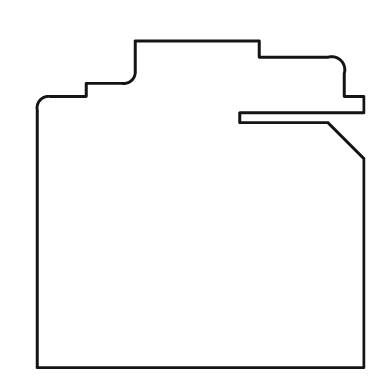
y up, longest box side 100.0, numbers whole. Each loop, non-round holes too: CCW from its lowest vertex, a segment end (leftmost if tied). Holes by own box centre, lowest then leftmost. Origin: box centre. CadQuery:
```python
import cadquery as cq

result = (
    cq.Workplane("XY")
    .moveTo(-50.0, -50.0)
    .lineTo(50.0, -50.0)
    .lineTo(50.0, 14.0)
    .lineTo(39.0, 25.0)
    .lineTo(12.0, 25.0)
    .lineTo(12.0, 28.0)
    .lineTo(50.0, 28.0)
    .lineTo(50.0, 33.0)
    .lineTo(44.0, 33.0)
    .lineTo(44.0, 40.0)
    .threePointArc((43.0, 44.0), (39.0, 45.0))
    .lineTo(18.0, 45.0)
    .lineTo(18.0, 50.0)
    .lineTo(-20.0, 50.0)
    .lineTo(-20.0, 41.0)
    .threePointArc((-21.0, 38.0), (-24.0, 37.0))
    .lineTo(-35.0, 37.0)
    .lineTo(-35.0, 33.0)
    .lineTo(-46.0, 33.0)
    .threePointArc((-49.0, 32.0), (-50.0, 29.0))
    .close()
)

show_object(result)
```